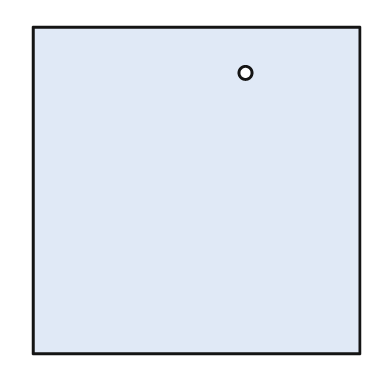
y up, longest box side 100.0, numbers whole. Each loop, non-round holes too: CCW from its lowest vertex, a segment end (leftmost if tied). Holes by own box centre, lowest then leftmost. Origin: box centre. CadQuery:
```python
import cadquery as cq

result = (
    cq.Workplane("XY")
    .moveTo(-50.0, -50.0)
    .lineTo(50.0, -50.0)
    .lineTo(50.0, 50.0)
    .lineTo(-50.0, 50.0)
    .close()
    .moveTo(15.0, 36.0)
    .circle(2.0)
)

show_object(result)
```